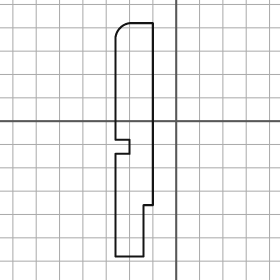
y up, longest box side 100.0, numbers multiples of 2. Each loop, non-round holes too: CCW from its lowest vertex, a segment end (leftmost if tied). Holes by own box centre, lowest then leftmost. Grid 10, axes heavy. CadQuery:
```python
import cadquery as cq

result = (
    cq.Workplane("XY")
    .moveTo(-26.0, -58.0)
    .lineTo(-14.0, -58.0)
    .lineTo(-14.0, -36.0)
    .lineTo(-10.0, -36.0)
    .lineTo(-10.0, 42.0)
    .lineTo(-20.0, 42.0)
    .threePointArc((-24.0, 40.0), (-26.0, 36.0))
    .lineTo(-26.0, -8.0)
    .lineTo(-20.0, -8.0)
    .lineTo(-20.0, -14.0)
    .lineTo(-26.0, -14.0)
    .close()
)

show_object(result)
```